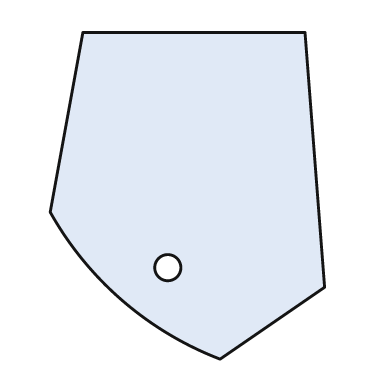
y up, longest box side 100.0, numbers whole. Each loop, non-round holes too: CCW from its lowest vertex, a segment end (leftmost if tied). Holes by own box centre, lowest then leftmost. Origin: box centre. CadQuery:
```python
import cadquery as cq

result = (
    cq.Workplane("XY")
    .moveTo(10.0, -50.0)
    .lineTo(42.0, -28.0)
    .lineTo(36.0, 50.0)
    .lineTo(-32.0, 50.0)
    .lineTo(-42.0, -5.0)
    .threePointArc((-20.0, -32.0), (10.0, -50.0))
    .close()
    .moveTo(-6.0, -22.0)
    .circle(4.0)
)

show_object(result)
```